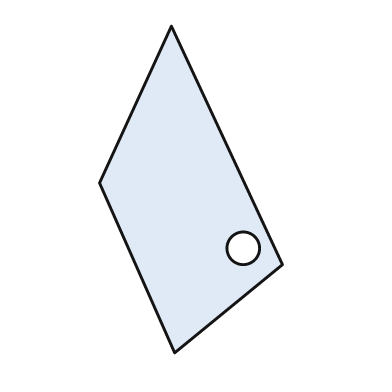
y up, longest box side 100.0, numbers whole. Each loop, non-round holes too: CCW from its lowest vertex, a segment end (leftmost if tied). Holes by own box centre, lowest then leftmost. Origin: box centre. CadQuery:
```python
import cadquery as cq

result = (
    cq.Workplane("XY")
    .moveTo(-5.0, -50.0)
    .lineTo(28.0, -23.0)
    .lineTo(-6.0, 50.0)
    .lineTo(-28.0, 2.0)
    .close()
    .moveTo(16.0, -18.0)
    .circle(5.0)
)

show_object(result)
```